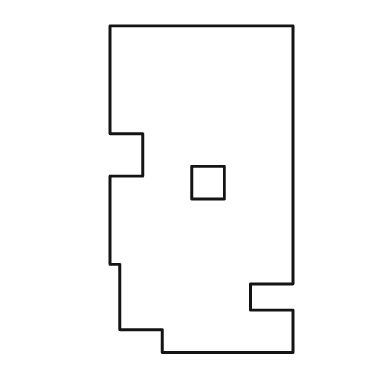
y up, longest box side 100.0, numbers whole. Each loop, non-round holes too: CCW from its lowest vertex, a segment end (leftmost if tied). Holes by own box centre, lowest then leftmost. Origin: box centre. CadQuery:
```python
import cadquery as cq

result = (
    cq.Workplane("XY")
    .moveTo(-12.0, -50.0)
    .lineTo(28.0, -50.0)
    .lineTo(28.0, -37.0)
    .lineTo(15.0, -37.0)
    .lineTo(15.0, -29.0)
    .lineTo(28.0, -29.0)
    .lineTo(28.0, 50.0)
    .lineTo(-28.0, 50.0)
    .lineTo(-28.0, 17.0)
    .lineTo(-18.0, 17.0)
    .lineTo(-18.0, 4.0)
    .lineTo(-28.0, 4.0)
    .lineTo(-28.0, -23.0)
    .lineTo(-25.0, -23.0)
    .lineTo(-25.0, -43.0)
    .lineTo(-12.0, -43.0)
    .close()
    .moveTo(-3.0, -3.0)
    .lineTo(7.0, -3.0)
    .lineTo(7.0, 7.0)
    .lineTo(-3.0, 7.0)
    .close()
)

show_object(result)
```